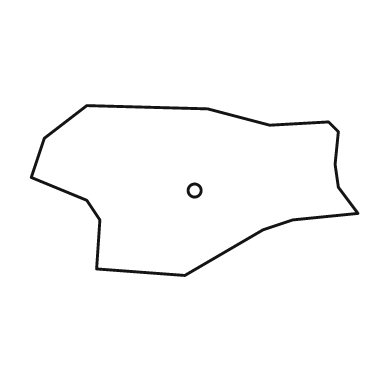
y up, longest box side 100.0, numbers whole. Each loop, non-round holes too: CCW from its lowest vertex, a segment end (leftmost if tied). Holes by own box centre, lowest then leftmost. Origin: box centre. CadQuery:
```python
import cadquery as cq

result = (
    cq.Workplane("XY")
    .moveTo(-3.0, -26.0)
    .lineTo(21.0, -12.0)
    .lineTo(30.0, -9.0)
    .lineTo(50.0, -7.0)
    .lineTo(44.0, 1.0)
    .lineTo(43.0, 8.0)
    .lineTo(44.0, 18.0)
    .lineTo(41.0, 21.0)
    .lineTo(23.0, 20.0)
    .lineTo(4.0, 25.0)
    .lineTo(-33.0, 26.0)
    .lineTo(-46.0, 16.0)
    .lineTo(-50.0, 4.0)
    .lineTo(-33.0, -3.0)
    .lineTo(-29.0, -9.0)
    .lineTo(-30.0, -24.0)
    .close()
    .moveTo(0.0, 0.0)
    .circle(2.0)
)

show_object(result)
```